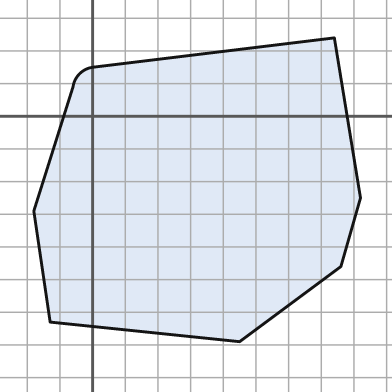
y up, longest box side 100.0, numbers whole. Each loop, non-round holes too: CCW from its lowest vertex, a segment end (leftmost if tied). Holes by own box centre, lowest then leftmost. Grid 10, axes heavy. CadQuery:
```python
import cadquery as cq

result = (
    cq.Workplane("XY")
    .moveTo(45.0, -69.0)
    .lineTo(76.0, -46.0)
    .lineTo(82.0, -25.0)
    .lineTo(74.0, 24.0)
    .lineTo(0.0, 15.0)
    .threePointArc((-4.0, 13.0), (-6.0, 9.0))
    .lineTo(-18.0, -29.0)
    .lineTo(-13.0, -63.0)
    .close()
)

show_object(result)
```